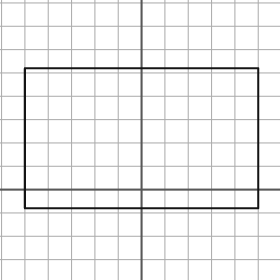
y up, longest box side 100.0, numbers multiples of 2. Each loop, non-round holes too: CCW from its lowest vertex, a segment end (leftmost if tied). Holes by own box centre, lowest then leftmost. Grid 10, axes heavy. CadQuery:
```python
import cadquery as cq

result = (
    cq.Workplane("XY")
    .moveTo(-50.0, -8.0)
    .lineTo(50.0, -8.0)
    .lineTo(50.0, 52.0)
    .lineTo(-50.0, 52.0)
    .close()
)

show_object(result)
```